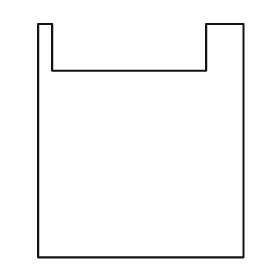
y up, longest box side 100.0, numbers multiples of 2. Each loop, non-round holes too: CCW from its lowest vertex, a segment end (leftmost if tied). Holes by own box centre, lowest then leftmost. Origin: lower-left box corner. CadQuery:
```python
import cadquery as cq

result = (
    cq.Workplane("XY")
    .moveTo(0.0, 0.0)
    .lineTo(88.0, 0.0)
    .lineTo(88.0, 100.0)
    .lineTo(72.0, 100.0)
    .lineTo(72.0, 80.0)
    .lineTo(6.0, 80.0)
    .lineTo(6.0, 100.0)
    .lineTo(0.0, 100.0)
    .close()
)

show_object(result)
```